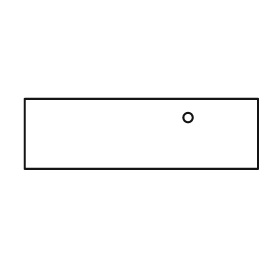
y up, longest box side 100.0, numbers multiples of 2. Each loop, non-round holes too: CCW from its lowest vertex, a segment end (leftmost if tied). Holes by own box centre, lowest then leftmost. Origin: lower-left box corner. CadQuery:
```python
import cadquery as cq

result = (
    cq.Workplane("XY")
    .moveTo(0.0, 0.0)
    .lineTo(100.0, 0.0)
    .lineTo(100.0, 30.0)
    .lineTo(0.0, 30.0)
    .close()
    .moveTo(70.0, 22.0)
    .circle(2.0)
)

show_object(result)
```